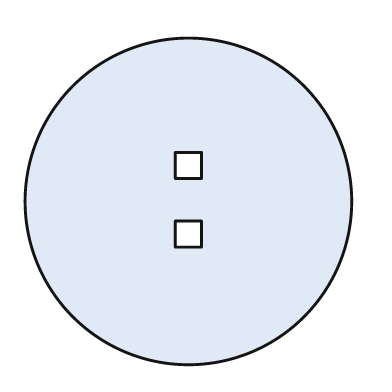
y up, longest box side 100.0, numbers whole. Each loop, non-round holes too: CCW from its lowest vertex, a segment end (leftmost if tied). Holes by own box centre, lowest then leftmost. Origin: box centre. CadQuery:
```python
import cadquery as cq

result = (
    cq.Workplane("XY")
    .moveTo(0.0, 0.0)
    .circle(50.0)
    .moveTo(-4.0, -14.0)
    .lineTo(4.0, -14.0)
    .lineTo(4.0, -6.0)
    .lineTo(-4.0, -6.0)
    .close()
    .moveTo(-4.0, 7.0)
    .lineTo(4.0, 7.0)
    .lineTo(4.0, 15.0)
    .lineTo(-4.0, 15.0)
    .close()
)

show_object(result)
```